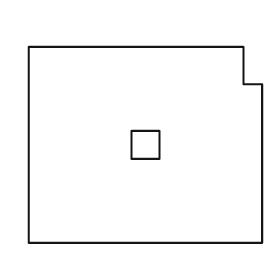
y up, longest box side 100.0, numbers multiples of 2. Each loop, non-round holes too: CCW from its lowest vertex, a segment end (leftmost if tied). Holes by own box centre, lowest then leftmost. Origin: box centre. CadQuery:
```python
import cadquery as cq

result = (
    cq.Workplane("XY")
    .moveTo(-50.0, -42.0)
    .lineTo(50.0, -42.0)
    .lineTo(50.0, 26.0)
    .lineTo(42.0, 26.0)
    .lineTo(42.0, 42.0)
    .lineTo(-50.0, 42.0)
    .close()
    .moveTo(-6.0, -6.0)
    .lineTo(6.0, -6.0)
    .lineTo(6.0, 6.0)
    .lineTo(-6.0, 6.0)
    .close()
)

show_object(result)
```